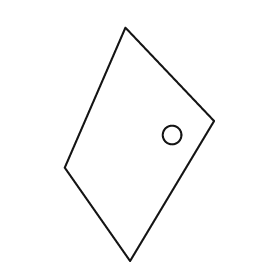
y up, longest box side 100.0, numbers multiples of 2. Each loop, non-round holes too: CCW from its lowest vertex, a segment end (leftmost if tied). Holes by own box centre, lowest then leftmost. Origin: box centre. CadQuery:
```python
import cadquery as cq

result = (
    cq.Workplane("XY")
    .moveTo(-4.0, -50.0)
    .lineTo(32.0, 10.0)
    .lineTo(-6.0, 50.0)
    .lineTo(-32.0, -10.0)
    .close()
    .moveTo(14.0, 4.0)
    .circle(4.0)
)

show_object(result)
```